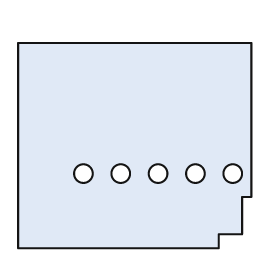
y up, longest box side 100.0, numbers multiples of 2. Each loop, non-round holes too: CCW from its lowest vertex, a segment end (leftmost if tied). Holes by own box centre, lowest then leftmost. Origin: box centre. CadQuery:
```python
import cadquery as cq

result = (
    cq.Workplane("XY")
    .moveTo(-50.0, -44.0)
    .lineTo(36.0, -44.0)
    .lineTo(36.0, -38.0)
    .lineTo(46.0, -38.0)
    .lineTo(46.0, -22.0)
    .lineTo(50.0, -22.0)
    .lineTo(50.0, 44.0)
    .lineTo(-50.0, 44.0)
    .close()
    .moveTo(-22.0, -12.0)
    .circle(4.0)
    .moveTo(-6.0, -12.0)
    .circle(4.0)
    .moveTo(10.0, -12.0)
    .circle(4.0)
    .moveTo(26.0, -12.0)
    .circle(4.0)
    .moveTo(42.0, -12.0)
    .circle(4.0)
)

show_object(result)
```